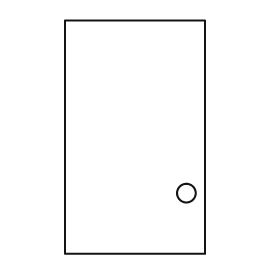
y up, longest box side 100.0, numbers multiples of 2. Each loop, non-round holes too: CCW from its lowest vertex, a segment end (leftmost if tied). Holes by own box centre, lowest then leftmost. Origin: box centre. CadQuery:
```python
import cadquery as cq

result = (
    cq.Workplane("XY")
    .moveTo(-30.0, -50.0)
    .lineTo(30.0, -50.0)
    .lineTo(30.0, 50.0)
    .lineTo(-30.0, 50.0)
    .close()
    .moveTo(22.0, -24.0)
    .circle(4.0)
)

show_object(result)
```